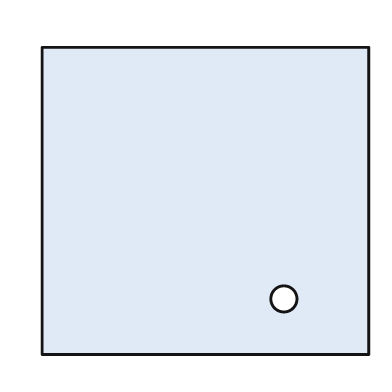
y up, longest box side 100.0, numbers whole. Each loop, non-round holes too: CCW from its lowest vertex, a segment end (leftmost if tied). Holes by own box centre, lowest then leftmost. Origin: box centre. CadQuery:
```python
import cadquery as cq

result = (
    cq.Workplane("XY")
    .moveTo(-50.0, -47.0)
    .lineTo(50.0, -47.0)
    .lineTo(50.0, 47.0)
    .lineTo(-50.0, 47.0)
    .close()
    .moveTo(24.0, -30.0)
    .circle(4.0)
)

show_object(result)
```